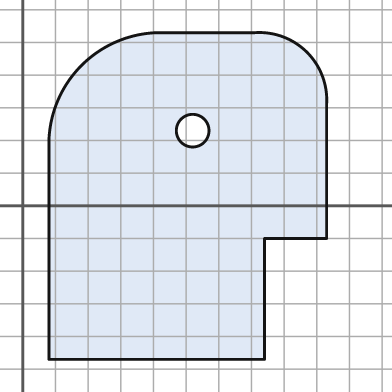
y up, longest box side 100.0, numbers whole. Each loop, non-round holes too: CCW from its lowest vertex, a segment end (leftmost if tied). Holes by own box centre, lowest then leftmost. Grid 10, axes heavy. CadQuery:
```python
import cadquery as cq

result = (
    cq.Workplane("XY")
    .moveTo(8.0, -47.0)
    .lineTo(74.0, -47.0)
    .lineTo(74.0, -10.0)
    .lineTo(93.0, -10.0)
    .lineTo(93.0, 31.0)
    .threePointArc((87.0, 47.0), (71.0, 53.0))
    .lineTo(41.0, 53.0)
    .threePointArc((18.0, 43.0), (8.0, 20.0))
    .close()
    .moveTo(52.0, 23.0)
    .circle(5.0)
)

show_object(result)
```